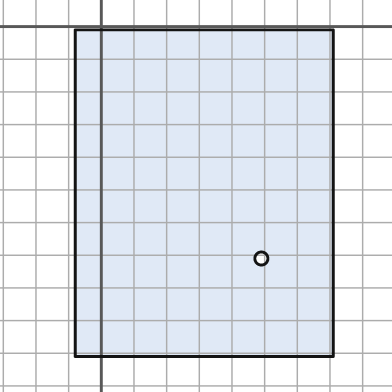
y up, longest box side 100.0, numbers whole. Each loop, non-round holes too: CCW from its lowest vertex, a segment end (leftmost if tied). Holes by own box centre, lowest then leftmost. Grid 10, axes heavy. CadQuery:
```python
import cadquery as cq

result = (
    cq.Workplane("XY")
    .moveTo(-8.0, -101.0)
    .lineTo(71.0, -101.0)
    .lineTo(71.0, -1.0)
    .lineTo(-8.0, -1.0)
    .close()
    .moveTo(49.0, -71.0)
    .circle(2.0)
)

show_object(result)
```